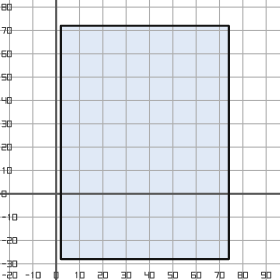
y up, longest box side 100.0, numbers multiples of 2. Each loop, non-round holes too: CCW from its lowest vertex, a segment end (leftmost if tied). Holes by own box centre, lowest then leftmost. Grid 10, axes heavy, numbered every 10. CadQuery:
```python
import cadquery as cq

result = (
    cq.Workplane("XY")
    .moveTo(2.0, -28.0)
    .lineTo(74.0, -28.0)
    .lineTo(74.0, 72.0)
    .lineTo(2.0, 72.0)
    .close()
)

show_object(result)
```